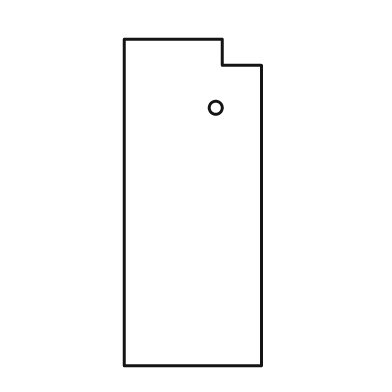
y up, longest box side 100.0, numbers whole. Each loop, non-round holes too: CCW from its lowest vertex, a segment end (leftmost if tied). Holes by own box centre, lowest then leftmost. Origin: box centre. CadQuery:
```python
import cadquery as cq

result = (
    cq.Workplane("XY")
    .moveTo(-21.0, -50.0)
    .lineTo(21.0, -50.0)
    .lineTo(21.0, 42.0)
    .lineTo(9.0, 42.0)
    .lineTo(9.0, 50.0)
    .lineTo(-21.0, 50.0)
    .close()
    .moveTo(7.0, 29.0)
    .circle(2.0)
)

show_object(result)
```